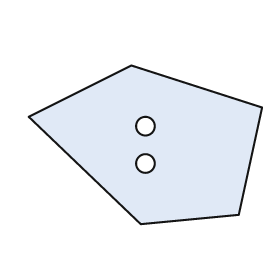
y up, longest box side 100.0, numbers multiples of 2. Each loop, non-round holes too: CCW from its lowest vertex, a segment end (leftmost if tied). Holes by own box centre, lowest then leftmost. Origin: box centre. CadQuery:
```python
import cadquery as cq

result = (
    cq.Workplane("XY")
    .moveTo(-2.0, -34.0)
    .lineTo(40.0, -30.0)
    .lineTo(50.0, 16.0)
    .lineTo(-6.0, 34.0)
    .lineTo(-50.0, 12.0)
    .close()
    .moveTo(0.0, -8.0)
    .circle(4.0)
    .moveTo(0.0, 8.0)
    .circle(4.0)
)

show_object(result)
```